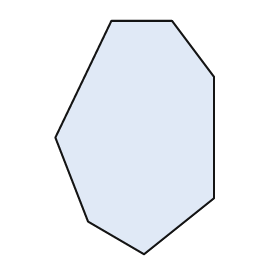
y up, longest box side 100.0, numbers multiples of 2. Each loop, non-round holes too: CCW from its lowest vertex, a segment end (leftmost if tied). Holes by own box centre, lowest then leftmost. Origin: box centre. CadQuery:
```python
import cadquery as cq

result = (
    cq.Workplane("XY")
    .moveTo(4.0, -50.0)
    .lineTo(34.0, -26.0)
    .lineTo(34.0, 26.0)
    .lineTo(16.0, 50.0)
    .lineTo(-10.0, 50.0)
    .lineTo(-34.0, 0.0)
    .lineTo(-20.0, -36.0)
    .close()
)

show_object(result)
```